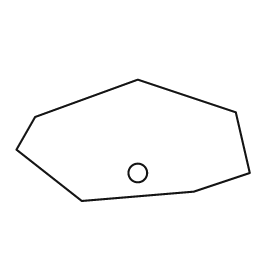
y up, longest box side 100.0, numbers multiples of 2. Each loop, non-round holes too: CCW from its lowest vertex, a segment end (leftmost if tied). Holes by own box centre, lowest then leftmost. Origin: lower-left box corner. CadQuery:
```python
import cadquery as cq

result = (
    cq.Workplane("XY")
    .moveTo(28.0, 0.0)
    .lineTo(76.0, 4.0)
    .lineTo(100.0, 12.0)
    .lineTo(94.0, 38.0)
    .lineTo(52.0, 52.0)
    .lineTo(8.0, 36.0)
    .lineTo(0.0, 22.0)
    .close()
    .moveTo(52.0, 12.0)
    .circle(4.0)
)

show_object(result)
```